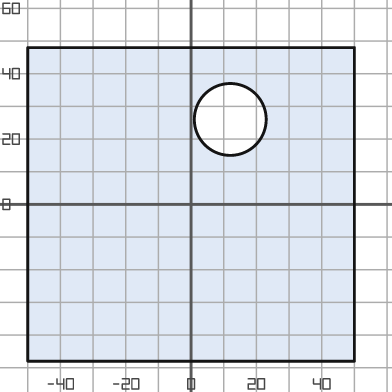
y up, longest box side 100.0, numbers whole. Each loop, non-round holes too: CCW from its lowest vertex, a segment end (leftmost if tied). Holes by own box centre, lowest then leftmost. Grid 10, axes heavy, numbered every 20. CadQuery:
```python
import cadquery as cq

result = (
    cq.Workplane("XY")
    .moveTo(-50.0, -48.0)
    .lineTo(50.0, -48.0)
    .lineTo(50.0, 48.0)
    .lineTo(-50.0, 48.0)
    .close()
    .moveTo(12.0, 26.0)
    .circle(11.0)
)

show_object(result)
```